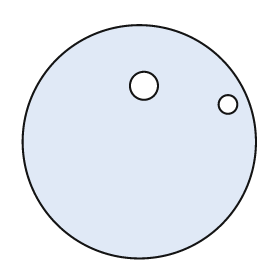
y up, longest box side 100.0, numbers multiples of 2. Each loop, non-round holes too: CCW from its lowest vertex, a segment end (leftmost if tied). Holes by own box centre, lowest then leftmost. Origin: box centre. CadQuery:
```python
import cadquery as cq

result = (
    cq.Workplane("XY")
    .moveTo(0.0, 0.0)
    .circle(50.0)
    .moveTo(38.0, 16.0)
    .circle(4.0)
    .moveTo(2.0, 24.0)
    .circle(6.0)
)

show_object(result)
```